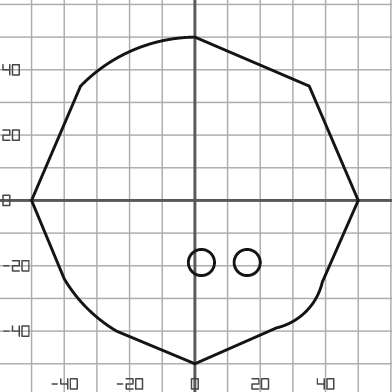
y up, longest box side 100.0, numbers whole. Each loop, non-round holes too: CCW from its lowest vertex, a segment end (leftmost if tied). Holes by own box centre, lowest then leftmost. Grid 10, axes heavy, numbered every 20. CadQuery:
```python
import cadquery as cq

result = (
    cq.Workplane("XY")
    .moveTo(0.0, -50.0)
    .lineTo(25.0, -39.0)
    .threePointArc((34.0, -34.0), (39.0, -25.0))
    .lineTo(50.0, 0.0)
    .lineTo(35.0, 35.0)
    .lineTo(0.0, 50.0)
    .threePointArc((-19.0, 46.0), (-35.0, 35.0))
    .lineTo(-50.0, 0.0)
    .lineTo(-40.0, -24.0)
    .threePointArc((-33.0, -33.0), (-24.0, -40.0))
    .close()
    .moveTo(2.0, -19.0)
    .circle(4.0)
    .moveTo(16.0, -19.0)
    .circle(4.0)
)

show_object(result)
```